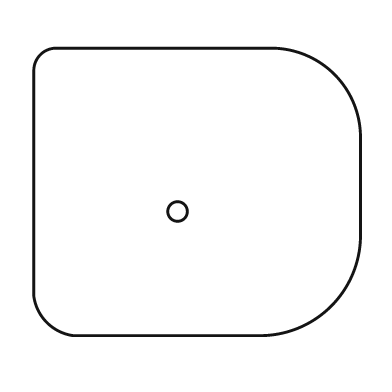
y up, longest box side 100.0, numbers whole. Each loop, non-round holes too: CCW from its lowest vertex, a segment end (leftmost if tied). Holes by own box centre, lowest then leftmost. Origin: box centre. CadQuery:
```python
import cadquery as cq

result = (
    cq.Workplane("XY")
    .moveTo(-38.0, -44.0)
    .lineTo(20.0, -44.0)
    .threePointArc((41.0, -35.0), (50.0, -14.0))
    .lineTo(50.0, 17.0)
    .threePointArc((42.0, 36.0), (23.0, 44.0))
    .lineTo(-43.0, 44.0)
    .threePointArc((-48.0, 42.0), (-50.0, 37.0))
    .lineTo(-50.0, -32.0)
    .threePointArc((-46.0, -40.0), (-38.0, -44.0))
    .close()
    .moveTo(-6.0, -6.0)
    .circle(3.0)
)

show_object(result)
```